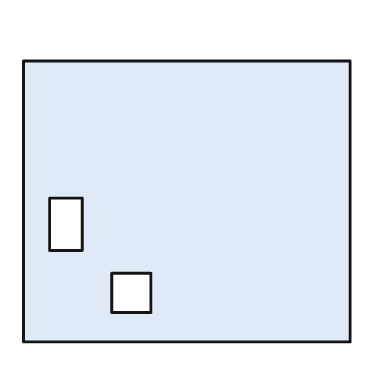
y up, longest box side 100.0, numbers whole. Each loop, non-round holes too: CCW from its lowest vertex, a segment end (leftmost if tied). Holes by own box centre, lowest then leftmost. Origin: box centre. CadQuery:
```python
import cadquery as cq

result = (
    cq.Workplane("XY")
    .moveTo(-50.0, -43.0)
    .lineTo(50.0, -43.0)
    .lineTo(50.0, 43.0)
    .lineTo(-50.0, 43.0)
    .close()
    .moveTo(-23.0, -34.0)
    .lineTo(-11.0, -34.0)
    .lineTo(-11.0, -22.0)
    .lineTo(-23.0, -22.0)
    .close()
    .moveTo(-42.0, -15.0)
    .lineTo(-32.0, -15.0)
    .lineTo(-32.0, 1.0)
    .lineTo(-42.0, 1.0)
    .close()
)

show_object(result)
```